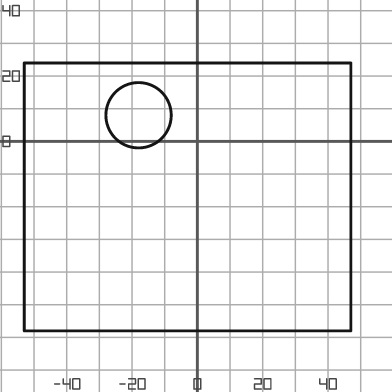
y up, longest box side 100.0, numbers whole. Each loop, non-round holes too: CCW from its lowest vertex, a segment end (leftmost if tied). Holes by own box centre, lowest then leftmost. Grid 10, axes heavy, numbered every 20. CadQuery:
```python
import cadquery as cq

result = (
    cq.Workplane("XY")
    .moveTo(-53.0, -58.0)
    .lineTo(47.0, -58.0)
    .lineTo(47.0, 24.0)
    .lineTo(-53.0, 24.0)
    .close()
    .moveTo(-18.0, 8.0)
    .circle(10.0)
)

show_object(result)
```